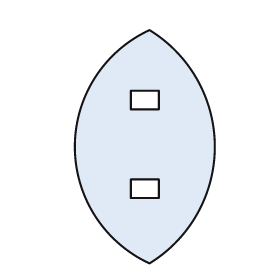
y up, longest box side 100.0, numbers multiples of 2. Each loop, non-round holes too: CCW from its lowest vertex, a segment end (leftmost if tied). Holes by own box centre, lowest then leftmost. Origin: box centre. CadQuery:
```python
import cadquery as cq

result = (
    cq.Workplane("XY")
    .moveTo(2.0, -50.0)
    .threePointArc((30.0, 0.0), (2.0, 50.0))
    .threePointArc((-30.0, 0.0), (2.0, -50.0))
    .close()
    .moveTo(-6.0, -22.0)
    .lineTo(6.0, -22.0)
    .lineTo(6.0, -14.0)
    .lineTo(-6.0, -14.0)
    .close()
    .moveTo(-6.0, 16.0)
    .lineTo(6.0, 16.0)
    .lineTo(6.0, 24.0)
    .lineTo(-6.0, 24.0)
    .close()
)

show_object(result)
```